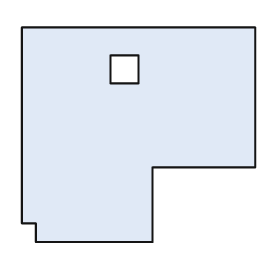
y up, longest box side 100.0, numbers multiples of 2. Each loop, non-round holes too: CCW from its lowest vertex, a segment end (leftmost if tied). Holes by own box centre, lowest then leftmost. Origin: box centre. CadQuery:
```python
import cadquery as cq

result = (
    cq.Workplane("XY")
    .moveTo(-44.0, -46.0)
    .lineTo(6.0, -46.0)
    .lineTo(6.0, -14.0)
    .lineTo(50.0, -14.0)
    .lineTo(50.0, 46.0)
    .lineTo(-50.0, 46.0)
    .lineTo(-50.0, -38.0)
    .lineTo(-44.0, -38.0)
    .close()
    .moveTo(-12.0, 22.0)
    .lineTo(0.0, 22.0)
    .lineTo(0.0, 34.0)
    .lineTo(-12.0, 34.0)
    .close()
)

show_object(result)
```